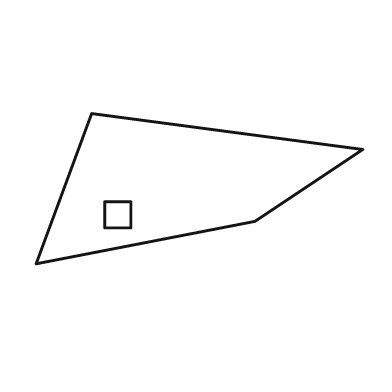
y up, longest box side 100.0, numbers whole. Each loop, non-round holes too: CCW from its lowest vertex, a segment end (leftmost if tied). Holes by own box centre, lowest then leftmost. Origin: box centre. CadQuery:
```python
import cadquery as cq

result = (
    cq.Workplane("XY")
    .moveTo(-50.0, -23.0)
    .lineTo(17.0, -10.0)
    .lineTo(50.0, 12.0)
    .lineTo(-33.0, 23.0)
    .close()
    .moveTo(-29.0, -12.0)
    .lineTo(-21.0, -12.0)
    .lineTo(-21.0, -4.0)
    .lineTo(-29.0, -4.0)
    .close()
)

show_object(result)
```